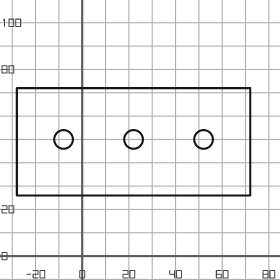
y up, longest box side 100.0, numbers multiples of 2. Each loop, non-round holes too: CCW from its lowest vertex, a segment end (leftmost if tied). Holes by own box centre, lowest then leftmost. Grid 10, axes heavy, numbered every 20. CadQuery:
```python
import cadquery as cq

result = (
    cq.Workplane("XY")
    .moveTo(-28.0, 26.0)
    .lineTo(72.0, 26.0)
    .lineTo(72.0, 72.0)
    .lineTo(-28.0, 72.0)
    .close()
    .moveTo(-8.0, 50.0)
    .circle(4.0)
    .moveTo(22.0, 50.0)
    .circle(4.0)
    .moveTo(52.0, 50.0)
    .circle(4.0)
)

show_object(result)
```